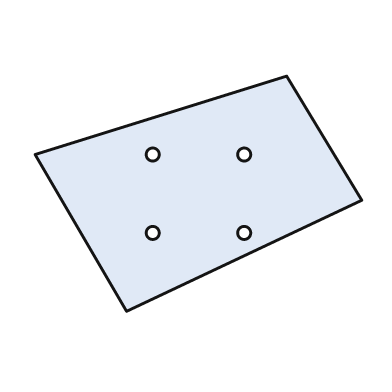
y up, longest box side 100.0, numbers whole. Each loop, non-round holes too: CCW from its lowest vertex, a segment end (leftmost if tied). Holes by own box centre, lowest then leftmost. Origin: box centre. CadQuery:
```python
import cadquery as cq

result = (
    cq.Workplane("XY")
    .moveTo(-22.0, -36.0)
    .lineTo(50.0, -2.0)
    .lineTo(27.0, 36.0)
    .lineTo(-50.0, 12.0)
    .close()
    .moveTo(-14.0, -12.0)
    .circle(2.0)
    .moveTo(14.0, -12.0)
    .circle(2.0)
    .moveTo(-14.0, 12.0)
    .circle(2.0)
    .moveTo(14.0, 12.0)
    .circle(2.0)
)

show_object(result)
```